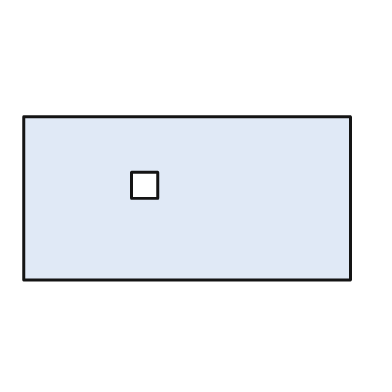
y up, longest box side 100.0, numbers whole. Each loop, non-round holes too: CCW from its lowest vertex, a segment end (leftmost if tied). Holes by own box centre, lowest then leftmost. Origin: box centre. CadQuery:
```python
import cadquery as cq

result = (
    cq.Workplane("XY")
    .moveTo(-50.0, -25.0)
    .lineTo(50.0, -25.0)
    .lineTo(50.0, 25.0)
    .lineTo(-50.0, 25.0)
    .close()
    .moveTo(-17.0, 0.0)
    .lineTo(-9.0, 0.0)
    .lineTo(-9.0, 8.0)
    .lineTo(-17.0, 8.0)
    .close()
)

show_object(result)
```